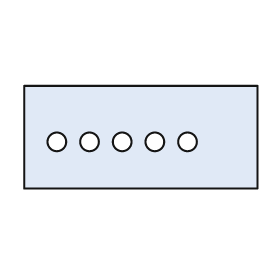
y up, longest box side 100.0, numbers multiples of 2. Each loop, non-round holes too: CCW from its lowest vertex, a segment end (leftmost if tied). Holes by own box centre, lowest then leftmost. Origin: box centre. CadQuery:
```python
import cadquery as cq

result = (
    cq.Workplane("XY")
    .moveTo(-50.0, -22.0)
    .lineTo(50.0, -22.0)
    .lineTo(50.0, 22.0)
    .lineTo(-50.0, 22.0)
    .close()
    .moveTo(-36.0, -2.0)
    .circle(4.0)
    .moveTo(-22.0, -2.0)
    .circle(4.0)
    .moveTo(-8.0, -2.0)
    .circle(4.0)
    .moveTo(6.0, -2.0)
    .circle(4.0)
    .moveTo(20.0, -2.0)
    .circle(4.0)
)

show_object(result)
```